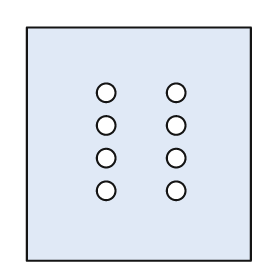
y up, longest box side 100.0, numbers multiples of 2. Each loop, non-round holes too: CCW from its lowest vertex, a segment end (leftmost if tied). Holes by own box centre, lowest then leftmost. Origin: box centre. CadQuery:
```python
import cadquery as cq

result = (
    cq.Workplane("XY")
    .moveTo(-48.0, -50.0)
    .lineTo(48.0, -50.0)
    .lineTo(48.0, 50.0)
    .lineTo(-48.0, 50.0)
    .close()
    .moveTo(-14.0, -20.0)
    .circle(4.0)
    .moveTo(16.0, -20.0)
    .circle(4.0)
    .moveTo(-14.0, -6.0)
    .circle(4.0)
    .moveTo(16.0, -6.0)
    .circle(4.0)
    .moveTo(-14.0, 8.0)
    .circle(4.0)
    .moveTo(16.0, 8.0)
    .circle(4.0)
    .moveTo(-14.0, 22.0)
    .circle(4.0)
    .moveTo(16.0, 22.0)
    .circle(4.0)
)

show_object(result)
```